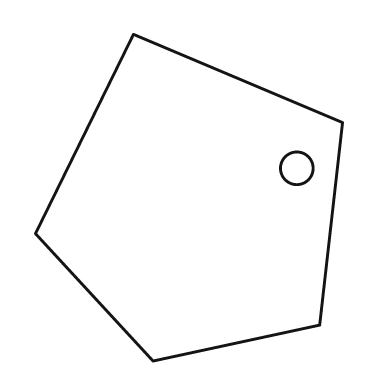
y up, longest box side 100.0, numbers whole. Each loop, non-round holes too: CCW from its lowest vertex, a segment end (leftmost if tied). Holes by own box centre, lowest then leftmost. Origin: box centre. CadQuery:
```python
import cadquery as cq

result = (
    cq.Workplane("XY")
    .moveTo(-11.0, -50.0)
    .lineTo(40.0, -39.0)
    .lineTo(47.0, 23.0)
    .lineTo(-17.0, 50.0)
    .lineTo(-47.0, -11.0)
    .close()
    .moveTo(33.0, 9.0)
    .circle(5.0)
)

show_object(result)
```